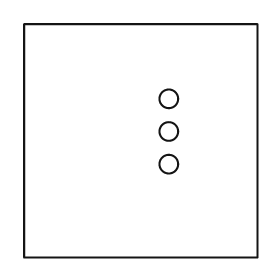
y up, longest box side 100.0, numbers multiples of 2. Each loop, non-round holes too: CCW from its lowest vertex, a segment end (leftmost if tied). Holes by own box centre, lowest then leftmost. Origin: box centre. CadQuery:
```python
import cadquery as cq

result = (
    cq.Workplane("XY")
    .moveTo(-50.0, -50.0)
    .lineTo(50.0, -50.0)
    .lineTo(50.0, 50.0)
    .lineTo(-50.0, 50.0)
    .close()
    .moveTo(12.0, -10.0)
    .circle(4.0)
    .moveTo(12.0, 4.0)
    .circle(4.0)
    .moveTo(12.0, 18.0)
    .circle(4.0)
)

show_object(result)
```